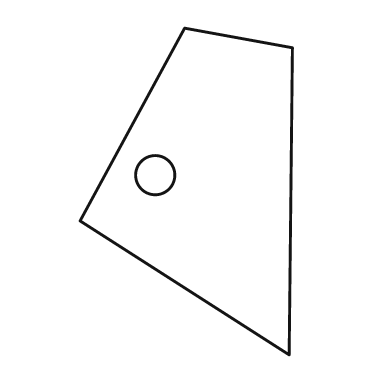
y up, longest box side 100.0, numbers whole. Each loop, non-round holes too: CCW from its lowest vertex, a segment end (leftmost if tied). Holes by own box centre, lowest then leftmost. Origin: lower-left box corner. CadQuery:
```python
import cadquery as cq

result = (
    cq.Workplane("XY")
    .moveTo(64.0, 0.0)
    .lineTo(65.0, 94.0)
    .lineTo(32.0, 100.0)
    .lineTo(0.0, 41.0)
    .close()
    .moveTo(23.0, 55.0)
    .circle(6.0)
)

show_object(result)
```